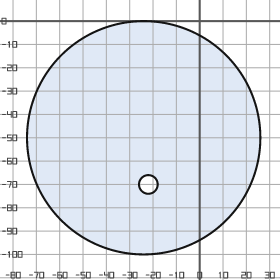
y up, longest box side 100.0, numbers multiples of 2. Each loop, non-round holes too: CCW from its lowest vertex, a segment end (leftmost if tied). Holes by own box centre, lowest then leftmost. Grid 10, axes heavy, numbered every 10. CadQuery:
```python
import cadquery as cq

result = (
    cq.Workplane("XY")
    .moveTo(-24.0, -50.0)
    .circle(50.0)
    .moveTo(-22.0, -70.0)
    .circle(4.0)
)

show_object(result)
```